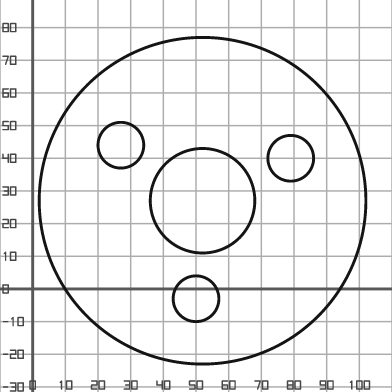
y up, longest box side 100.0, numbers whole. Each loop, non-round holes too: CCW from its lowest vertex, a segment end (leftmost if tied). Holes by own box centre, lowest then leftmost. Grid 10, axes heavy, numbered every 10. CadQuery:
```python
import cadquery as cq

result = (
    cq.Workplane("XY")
    .moveTo(52.0, 27.0)
    .circle(50.0)
    .moveTo(50.0, -3.0)
    .circle(7.0)
    .moveTo(52.0, 27.0)
    .circle(16.0)
    .moveTo(79.0, 40.0)
    .circle(7.0)
    .moveTo(27.0, 44.0)
    .circle(7.0)
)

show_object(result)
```